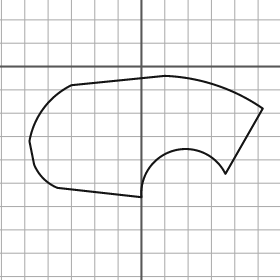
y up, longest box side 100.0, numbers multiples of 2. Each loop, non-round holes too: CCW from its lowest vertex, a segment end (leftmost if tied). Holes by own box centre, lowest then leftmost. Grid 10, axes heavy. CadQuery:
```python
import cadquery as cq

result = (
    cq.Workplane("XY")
    .moveTo(0.0, -56.0)
    .threePointArc((14.0, -36.0), (36.0, -46.0))
    .lineTo(52.0, -18.0)
    .threePointArc((32.0, -8.0), (10.0, -4.0))
    .lineTo(-30.0, -8.0)
    .threePointArc((-42.0, -18.0), (-48.0, -32.0))
    .lineTo(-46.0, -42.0)
    .threePointArc((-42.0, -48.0), (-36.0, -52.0))
    .close()
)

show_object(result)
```